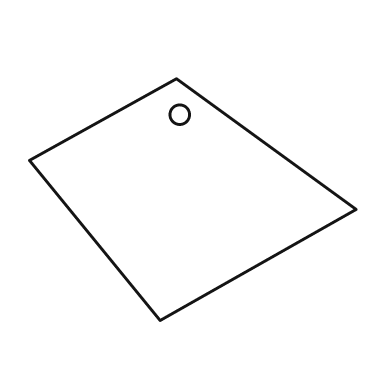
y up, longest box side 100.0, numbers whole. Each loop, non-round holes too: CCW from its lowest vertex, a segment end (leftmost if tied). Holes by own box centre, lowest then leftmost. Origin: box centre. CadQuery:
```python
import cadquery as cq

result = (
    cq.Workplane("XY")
    .moveTo(-10.0, -37.0)
    .lineTo(50.0, -3.0)
    .lineTo(-5.0, 37.0)
    .lineTo(-50.0, 12.0)
    .close()
    .moveTo(-4.0, 26.0)
    .circle(3.0)
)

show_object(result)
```